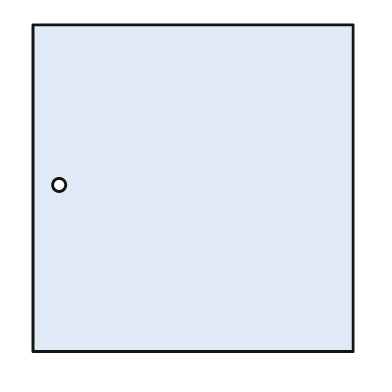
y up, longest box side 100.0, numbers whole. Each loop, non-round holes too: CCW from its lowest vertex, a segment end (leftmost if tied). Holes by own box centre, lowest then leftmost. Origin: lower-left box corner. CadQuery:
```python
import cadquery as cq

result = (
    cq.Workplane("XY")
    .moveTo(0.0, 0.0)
    .lineTo(98.0, 0.0)
    .lineTo(98.0, 100.0)
    .lineTo(0.0, 100.0)
    .close()
    .moveTo(8.0, 51.0)
    .circle(2.0)
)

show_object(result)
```